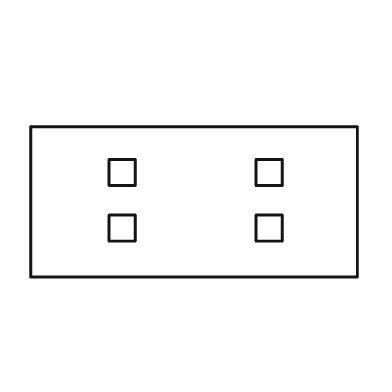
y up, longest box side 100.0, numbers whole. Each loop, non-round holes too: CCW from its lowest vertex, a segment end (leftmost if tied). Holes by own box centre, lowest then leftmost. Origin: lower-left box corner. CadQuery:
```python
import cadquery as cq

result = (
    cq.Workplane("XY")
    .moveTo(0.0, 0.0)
    .lineTo(100.0, 0.0)
    .lineTo(100.0, 46.0)
    .lineTo(0.0, 46.0)
    .close()
    .moveTo(24.0, 11.0)
    .lineTo(32.0, 11.0)
    .lineTo(32.0, 19.0)
    .lineTo(24.0, 19.0)
    .close()
    .moveTo(69.0, 11.0)
    .lineTo(77.0, 11.0)
    .lineTo(77.0, 19.0)
    .lineTo(69.0, 19.0)
    .close()
    .moveTo(24.0, 28.0)
    .lineTo(32.0, 28.0)
    .lineTo(32.0, 36.0)
    .lineTo(24.0, 36.0)
    .close()
    .moveTo(69.0, 28.0)
    .lineTo(77.0, 28.0)
    .lineTo(77.0, 36.0)
    .lineTo(69.0, 36.0)
    .close()
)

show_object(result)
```